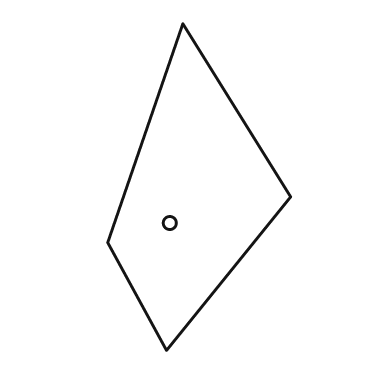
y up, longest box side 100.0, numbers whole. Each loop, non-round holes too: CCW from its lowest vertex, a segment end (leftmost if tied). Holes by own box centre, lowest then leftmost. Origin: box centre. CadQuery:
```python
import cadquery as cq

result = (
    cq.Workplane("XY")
    .moveTo(-10.0, -50.0)
    .lineTo(28.0, -3.0)
    .lineTo(-5.0, 50.0)
    .lineTo(-28.0, -17.0)
    .close()
    .moveTo(-9.0, -11.0)
    .circle(2.0)
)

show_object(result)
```